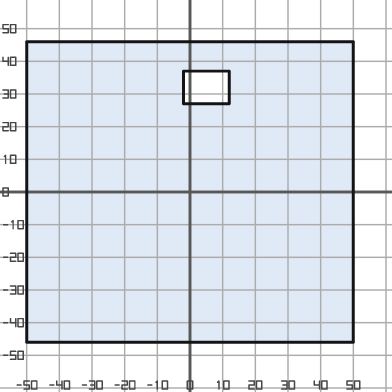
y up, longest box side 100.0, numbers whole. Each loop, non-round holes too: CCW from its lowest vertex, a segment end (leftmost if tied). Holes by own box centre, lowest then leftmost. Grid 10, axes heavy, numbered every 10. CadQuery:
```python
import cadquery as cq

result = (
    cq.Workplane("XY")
    .moveTo(-50.0, -46.0)
    .lineTo(50.0, -46.0)
    .lineTo(50.0, 46.0)
    .lineTo(-50.0, 46.0)
    .close()
    .moveTo(-2.0, 27.0)
    .lineTo(12.0, 27.0)
    .lineTo(12.0, 37.0)
    .lineTo(-2.0, 37.0)
    .close()
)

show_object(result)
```